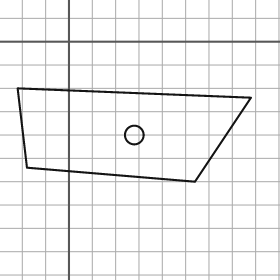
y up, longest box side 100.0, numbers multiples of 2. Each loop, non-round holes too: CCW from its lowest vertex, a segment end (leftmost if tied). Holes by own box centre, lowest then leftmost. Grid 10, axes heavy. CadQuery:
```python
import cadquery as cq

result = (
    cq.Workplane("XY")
    .moveTo(54.0, -60.0)
    .lineTo(78.0, -24.0)
    .lineTo(-22.0, -20.0)
    .lineTo(-18.0, -54.0)
    .close()
    .moveTo(28.0, -40.0)
    .circle(4.0)
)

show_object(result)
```